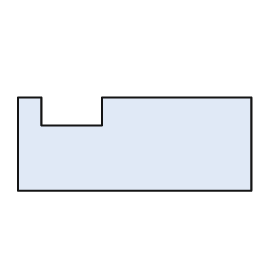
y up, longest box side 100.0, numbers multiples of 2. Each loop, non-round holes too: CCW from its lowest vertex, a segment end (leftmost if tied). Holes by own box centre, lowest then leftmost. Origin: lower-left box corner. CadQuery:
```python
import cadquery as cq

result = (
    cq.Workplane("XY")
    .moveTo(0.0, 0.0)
    .lineTo(100.0, 0.0)
    .lineTo(100.0, 40.0)
    .lineTo(36.0, 40.0)
    .lineTo(36.0, 28.0)
    .lineTo(10.0, 28.0)
    .lineTo(10.0, 40.0)
    .lineTo(0.0, 40.0)
    .close()
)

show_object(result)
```